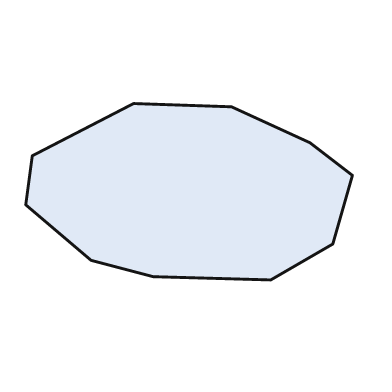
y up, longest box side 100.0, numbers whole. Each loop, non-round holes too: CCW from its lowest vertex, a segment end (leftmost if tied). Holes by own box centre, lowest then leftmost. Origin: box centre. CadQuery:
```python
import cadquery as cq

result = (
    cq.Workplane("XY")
    .moveTo(25.0, -27.0)
    .lineTo(44.0, -16.0)
    .lineTo(50.0, 5.0)
    .lineTo(37.0, 15.0)
    .lineTo(13.0, 26.0)
    .lineTo(-17.0, 27.0)
    .lineTo(-48.0, 11.0)
    .lineTo(-50.0, -4.0)
    .lineTo(-30.0, -21.0)
    .lineTo(-11.0, -26.0)
    .close()
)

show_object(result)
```